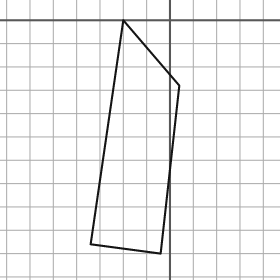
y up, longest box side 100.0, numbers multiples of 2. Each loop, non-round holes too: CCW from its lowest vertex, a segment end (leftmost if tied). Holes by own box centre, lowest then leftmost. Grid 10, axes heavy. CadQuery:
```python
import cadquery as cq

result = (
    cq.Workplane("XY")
    .moveTo(-4.0, -100.0)
    .lineTo(4.0, -28.0)
    .lineTo(-20.0, 0.0)
    .lineTo(-34.0, -96.0)
    .close()
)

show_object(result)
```